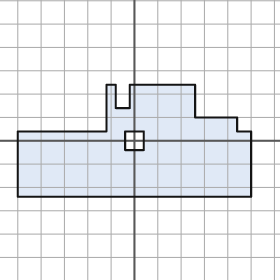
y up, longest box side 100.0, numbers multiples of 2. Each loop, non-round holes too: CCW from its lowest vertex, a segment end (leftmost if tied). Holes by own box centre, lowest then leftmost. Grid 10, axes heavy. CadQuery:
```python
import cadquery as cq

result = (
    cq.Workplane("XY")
    .moveTo(-50.0, -24.0)
    .lineTo(50.0, -24.0)
    .lineTo(50.0, 4.0)
    .lineTo(44.0, 4.0)
    .lineTo(44.0, 10.0)
    .lineTo(26.0, 10.0)
    .lineTo(26.0, 24.0)
    .lineTo(-2.0, 24.0)
    .lineTo(-2.0, 14.0)
    .lineTo(-8.0, 14.0)
    .lineTo(-8.0, 24.0)
    .lineTo(-12.0, 24.0)
    .lineTo(-12.0, 4.0)
    .lineTo(-50.0, 4.0)
    .close()
    .moveTo(-4.0, -4.0)
    .lineTo(4.0, -4.0)
    .lineTo(4.0, 4.0)
    .lineTo(-4.0, 4.0)
    .close()
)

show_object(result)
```